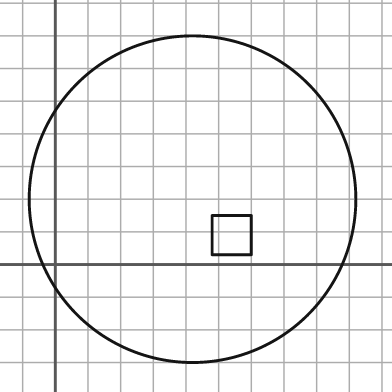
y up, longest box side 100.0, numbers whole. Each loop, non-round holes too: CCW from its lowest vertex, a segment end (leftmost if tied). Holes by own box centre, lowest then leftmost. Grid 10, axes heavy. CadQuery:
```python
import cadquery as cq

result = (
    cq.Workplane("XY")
    .moveTo(42.0, 20.0)
    .circle(50.0)
    .moveTo(48.0, 3.0)
    .lineTo(60.0, 3.0)
    .lineTo(60.0, 15.0)
    .lineTo(48.0, 15.0)
    .close()
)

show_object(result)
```